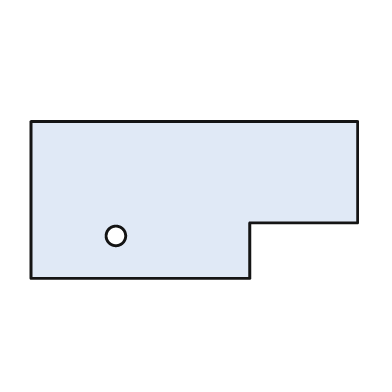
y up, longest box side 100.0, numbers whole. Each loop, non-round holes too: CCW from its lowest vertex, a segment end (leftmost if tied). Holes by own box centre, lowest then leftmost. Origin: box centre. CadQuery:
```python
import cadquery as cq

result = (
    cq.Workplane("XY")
    .moveTo(-50.0, -24.0)
    .lineTo(17.0, -24.0)
    .lineTo(17.0, -7.0)
    .lineTo(50.0, -7.0)
    .lineTo(50.0, 24.0)
    .lineTo(-50.0, 24.0)
    .close()
    .moveTo(-24.0, -11.0)
    .circle(3.0)
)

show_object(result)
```